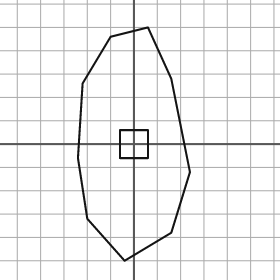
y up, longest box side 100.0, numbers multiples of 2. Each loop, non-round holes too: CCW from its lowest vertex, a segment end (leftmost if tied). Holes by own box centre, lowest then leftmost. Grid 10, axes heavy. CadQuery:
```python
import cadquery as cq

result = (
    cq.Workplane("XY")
    .moveTo(-4.0, -50.0)
    .lineTo(16.0, -38.0)
    .lineTo(24.0, -12.0)
    .lineTo(16.0, 28.0)
    .lineTo(6.0, 50.0)
    .lineTo(-10.0, 46.0)
    .lineTo(-22.0, 26.0)
    .lineTo(-24.0, -6.0)
    .lineTo(-20.0, -32.0)
    .close()
    .moveTo(-6.0, -6.0)
    .lineTo(6.0, -6.0)
    .lineTo(6.0, 6.0)
    .lineTo(-6.0, 6.0)
    .close()
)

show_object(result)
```